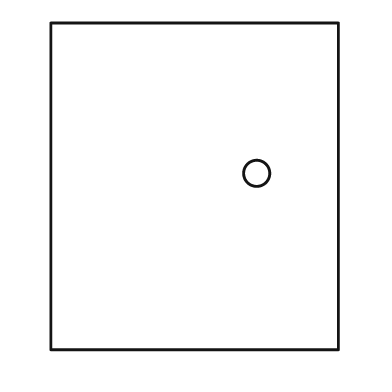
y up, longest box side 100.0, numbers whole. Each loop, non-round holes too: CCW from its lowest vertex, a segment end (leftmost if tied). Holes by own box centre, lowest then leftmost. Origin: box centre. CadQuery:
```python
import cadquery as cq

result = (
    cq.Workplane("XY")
    .moveTo(-44.0, -50.0)
    .lineTo(44.0, -50.0)
    .lineTo(44.0, 50.0)
    .lineTo(-44.0, 50.0)
    .close()
    .moveTo(19.0, 4.0)
    .circle(4.0)
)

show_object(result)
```